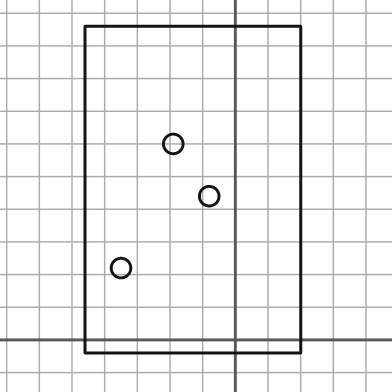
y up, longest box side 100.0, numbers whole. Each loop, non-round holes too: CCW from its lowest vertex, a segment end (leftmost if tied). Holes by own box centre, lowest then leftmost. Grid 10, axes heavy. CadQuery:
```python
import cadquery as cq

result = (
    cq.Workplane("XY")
    .moveTo(-46.0, -4.0)
    .lineTo(20.0, -4.0)
    .lineTo(20.0, 96.0)
    .lineTo(-46.0, 96.0)
    .close()
    .moveTo(-35.0, 22.0)
    .circle(3.0)
    .moveTo(-8.0, 44.0)
    .circle(3.0)
    .moveTo(-19.0, 60.0)
    .circle(3.0)
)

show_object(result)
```